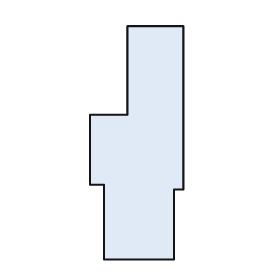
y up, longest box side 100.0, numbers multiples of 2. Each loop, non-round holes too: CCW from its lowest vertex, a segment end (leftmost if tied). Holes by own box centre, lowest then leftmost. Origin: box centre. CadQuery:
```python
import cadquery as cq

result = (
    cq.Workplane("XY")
    .moveTo(-14.0, -50.0)
    .lineTo(16.0, -50.0)
    .lineTo(16.0, -20.0)
    .lineTo(20.0, -20.0)
    .lineTo(20.0, 50.0)
    .lineTo(-4.0, 50.0)
    .lineTo(-4.0, 12.0)
    .lineTo(-20.0, 12.0)
    .lineTo(-20.0, -18.0)
    .lineTo(-14.0, -18.0)
    .close()
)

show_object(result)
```